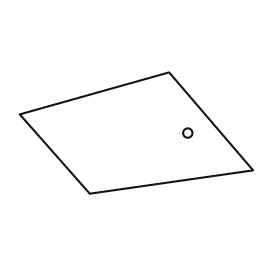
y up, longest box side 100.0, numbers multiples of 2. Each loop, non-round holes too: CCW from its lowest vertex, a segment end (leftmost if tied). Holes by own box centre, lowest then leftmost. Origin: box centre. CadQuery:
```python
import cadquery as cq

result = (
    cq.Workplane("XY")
    .moveTo(-20.0, -26.0)
    .lineTo(50.0, -16.0)
    .lineTo(14.0, 26.0)
    .lineTo(-50.0, 8.0)
    .close()
    .moveTo(22.0, 0.0)
    .circle(2.0)
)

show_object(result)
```